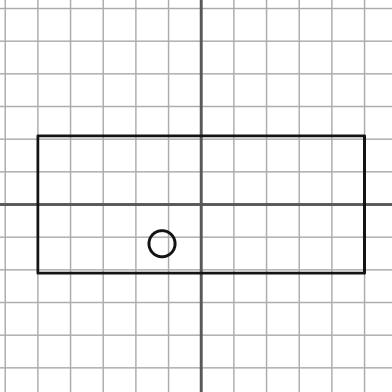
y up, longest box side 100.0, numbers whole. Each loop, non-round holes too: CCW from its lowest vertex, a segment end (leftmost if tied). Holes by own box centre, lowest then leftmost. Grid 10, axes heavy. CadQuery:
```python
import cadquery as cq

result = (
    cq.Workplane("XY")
    .moveTo(-50.0, -21.0)
    .lineTo(50.0, -21.0)
    .lineTo(50.0, 21.0)
    .lineTo(-50.0, 21.0)
    .close()
    .moveTo(-12.0, -12.0)
    .circle(4.0)
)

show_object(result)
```